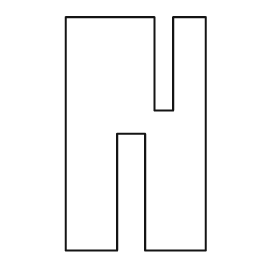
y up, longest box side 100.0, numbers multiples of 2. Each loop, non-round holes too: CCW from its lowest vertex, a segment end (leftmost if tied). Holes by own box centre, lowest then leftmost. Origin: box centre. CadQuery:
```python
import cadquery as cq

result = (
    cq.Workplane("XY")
    .moveTo(-30.0, -50.0)
    .lineTo(-8.0, -50.0)
    .lineTo(-8.0, 0.0)
    .lineTo(4.0, 0.0)
    .lineTo(4.0, -50.0)
    .lineTo(30.0, -50.0)
    .lineTo(30.0, 50.0)
    .lineTo(16.0, 50.0)
    .lineTo(16.0, 10.0)
    .lineTo(8.0, 10.0)
    .lineTo(8.0, 50.0)
    .lineTo(-30.0, 50.0)
    .close()
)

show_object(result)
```